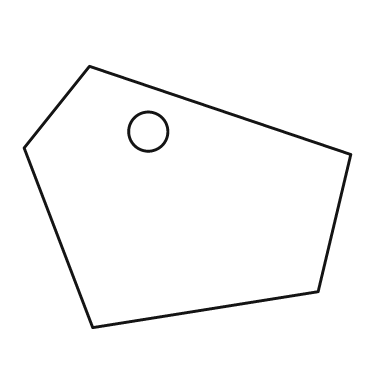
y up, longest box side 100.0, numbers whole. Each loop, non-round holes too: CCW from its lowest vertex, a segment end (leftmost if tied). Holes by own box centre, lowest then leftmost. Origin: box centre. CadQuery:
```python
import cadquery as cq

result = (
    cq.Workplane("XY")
    .moveTo(-29.0, -40.0)
    .lineTo(40.0, -29.0)
    .lineTo(50.0, 13.0)
    .lineTo(-30.0, 40.0)
    .lineTo(-50.0, 15.0)
    .close()
    .moveTo(-12.0, 20.0)
    .circle(6.0)
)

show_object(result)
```